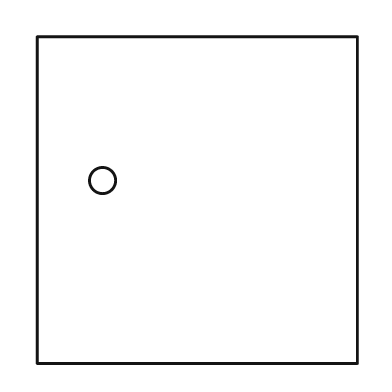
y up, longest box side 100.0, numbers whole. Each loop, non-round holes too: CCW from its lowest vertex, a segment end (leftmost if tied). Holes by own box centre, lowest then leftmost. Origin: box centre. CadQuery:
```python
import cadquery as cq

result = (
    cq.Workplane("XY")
    .moveTo(-49.0, -50.0)
    .lineTo(49.0, -50.0)
    .lineTo(49.0, 50.0)
    .lineTo(-49.0, 50.0)
    .close()
    .moveTo(-29.0, 6.0)
    .circle(4.0)
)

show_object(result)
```